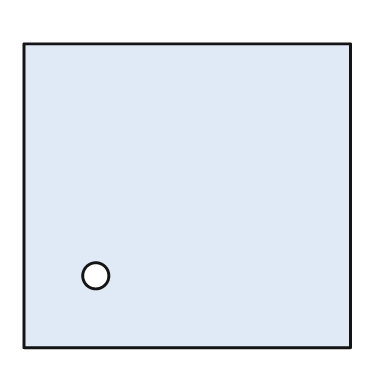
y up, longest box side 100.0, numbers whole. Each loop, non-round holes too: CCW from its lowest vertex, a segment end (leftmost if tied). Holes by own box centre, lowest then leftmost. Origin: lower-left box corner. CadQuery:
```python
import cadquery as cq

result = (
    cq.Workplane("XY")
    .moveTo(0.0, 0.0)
    .lineTo(100.0, 0.0)
    .lineTo(100.0, 93.0)
    .lineTo(0.0, 93.0)
    .close()
    .moveTo(22.0, 22.0)
    .circle(4.0)
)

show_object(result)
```